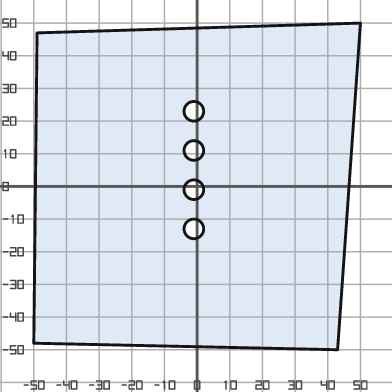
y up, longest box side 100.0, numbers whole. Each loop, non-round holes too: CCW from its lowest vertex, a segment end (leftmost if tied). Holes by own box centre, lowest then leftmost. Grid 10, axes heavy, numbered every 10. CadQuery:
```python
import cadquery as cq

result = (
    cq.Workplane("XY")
    .moveTo(43.0, -50.0)
    .lineTo(50.0, 50.0)
    .lineTo(-49.0, 47.0)
    .lineTo(-50.0, -48.0)
    .close()
    .moveTo(-1.0, -13.0)
    .circle(3.0)
    .moveTo(-1.0, -1.0)
    .circle(3.0)
    .moveTo(-1.0, 11.0)
    .circle(3.0)
    .moveTo(-1.0, 23.0)
    .circle(3.0)
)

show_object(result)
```